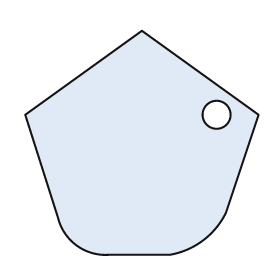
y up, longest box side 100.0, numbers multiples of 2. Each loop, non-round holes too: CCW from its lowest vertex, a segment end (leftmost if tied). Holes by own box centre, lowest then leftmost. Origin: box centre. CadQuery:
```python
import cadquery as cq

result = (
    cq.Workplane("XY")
    .moveTo(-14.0, -48.0)
    .lineTo(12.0, -48.0)
    .threePointArc((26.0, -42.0), (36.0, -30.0))
    .lineTo(50.0, 12.0)
    .lineTo(0.0, 48.0)
    .lineTo(-50.0, 12.0)
    .lineTo(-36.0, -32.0)
    .threePointArc((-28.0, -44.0), (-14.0, -48.0))
    .close()
    .moveTo(32.0, 12.0)
    .circle(6.0)
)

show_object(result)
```